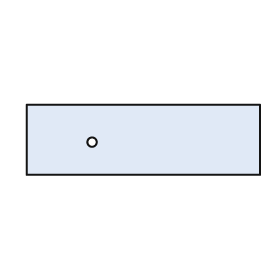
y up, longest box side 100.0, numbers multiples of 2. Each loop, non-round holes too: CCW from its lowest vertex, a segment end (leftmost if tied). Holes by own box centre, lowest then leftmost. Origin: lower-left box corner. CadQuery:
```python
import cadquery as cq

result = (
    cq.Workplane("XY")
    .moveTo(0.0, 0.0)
    .lineTo(100.0, 0.0)
    .lineTo(100.0, 30.0)
    .lineTo(0.0, 30.0)
    .close()
    .moveTo(28.0, 14.0)
    .circle(2.0)
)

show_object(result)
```